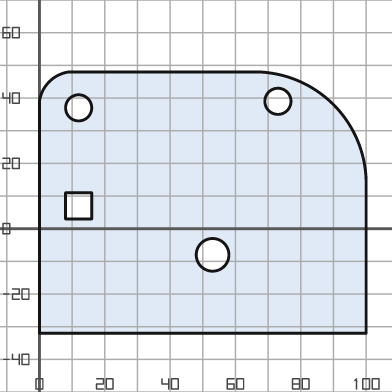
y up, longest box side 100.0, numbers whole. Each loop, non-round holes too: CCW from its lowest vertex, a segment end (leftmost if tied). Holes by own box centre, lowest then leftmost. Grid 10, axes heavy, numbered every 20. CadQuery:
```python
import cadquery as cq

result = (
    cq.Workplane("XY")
    .moveTo(0.0, -32.0)
    .lineTo(100.0, -32.0)
    .lineTo(100.0, 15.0)
    .threePointArc((90.0, 38.0), (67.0, 48.0))
    .lineTo(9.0, 48.0)
    .threePointArc((3.0, 45.0), (0.0, 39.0))
    .close()
    .moveTo(53.0, -8.0)
    .circle(5.0)
    .moveTo(8.0, 3.0)
    .lineTo(16.0, 3.0)
    .lineTo(16.0, 11.0)
    .lineTo(8.0, 11.0)
    .close()
    .moveTo(12.0, 37.0)
    .circle(4.0)
    .moveTo(73.0, 39.0)
    .circle(4.0)
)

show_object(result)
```